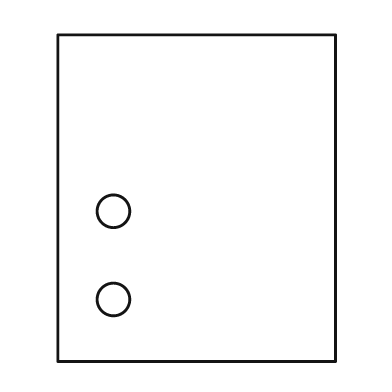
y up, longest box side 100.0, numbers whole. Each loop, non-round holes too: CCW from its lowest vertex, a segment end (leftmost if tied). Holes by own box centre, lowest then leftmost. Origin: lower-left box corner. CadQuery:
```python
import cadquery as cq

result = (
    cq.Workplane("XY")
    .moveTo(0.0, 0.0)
    .lineTo(85.0, 0.0)
    .lineTo(85.0, 100.0)
    .lineTo(0.0, 100.0)
    .close()
    .moveTo(17.0, 19.0)
    .circle(5.0)
    .moveTo(17.0, 46.0)
    .circle(5.0)
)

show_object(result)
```